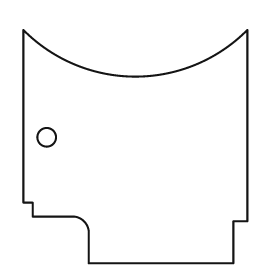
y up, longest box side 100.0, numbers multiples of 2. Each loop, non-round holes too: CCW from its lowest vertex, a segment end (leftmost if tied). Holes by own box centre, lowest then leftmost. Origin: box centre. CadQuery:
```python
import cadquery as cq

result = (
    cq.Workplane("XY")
    .moveTo(-20.0, -50.0)
    .lineTo(42.0, -50.0)
    .lineTo(42.0, -32.0)
    .lineTo(48.0, -32.0)
    .lineTo(48.0, 50.0)
    .threePointArc((0.0, 30.0), (-48.0, 50.0))
    .lineTo(-48.0, -24.0)
    .lineTo(-44.0, -24.0)
    .lineTo(-44.0, -30.0)
    .lineTo(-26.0, -30.0)
    .threePointArc((-22.0, -32.0), (-20.0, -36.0))
    .close()
    .moveTo(-38.0, 4.0)
    .circle(4.0)
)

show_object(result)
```